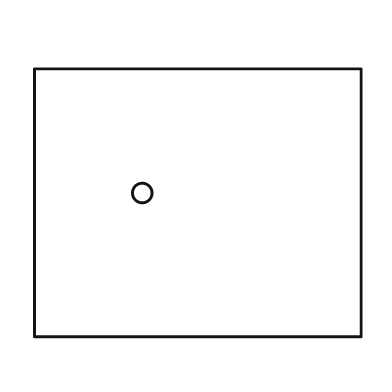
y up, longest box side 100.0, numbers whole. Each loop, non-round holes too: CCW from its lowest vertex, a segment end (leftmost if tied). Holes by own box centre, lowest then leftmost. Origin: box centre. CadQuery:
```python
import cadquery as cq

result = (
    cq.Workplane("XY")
    .moveTo(-50.0, -41.0)
    .lineTo(50.0, -41.0)
    .lineTo(50.0, 41.0)
    .lineTo(-50.0, 41.0)
    .close()
    .moveTo(-17.0, 3.0)
    .circle(3.0)
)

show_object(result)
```